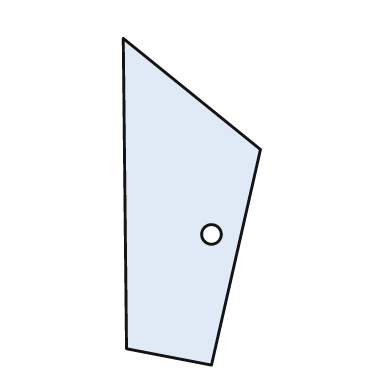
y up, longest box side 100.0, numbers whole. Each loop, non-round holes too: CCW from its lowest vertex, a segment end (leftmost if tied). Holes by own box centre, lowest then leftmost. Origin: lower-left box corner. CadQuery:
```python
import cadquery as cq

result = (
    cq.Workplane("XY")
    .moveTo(27.0, 0.0)
    .lineTo(42.0, 66.0)
    .lineTo(0.0, 100.0)
    .lineTo(1.0, 5.0)
    .close()
    .moveTo(27.0, 40.0)
    .circle(3.0)
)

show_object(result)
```